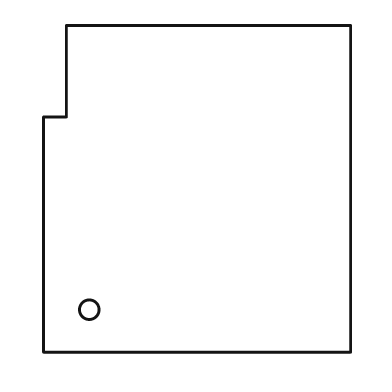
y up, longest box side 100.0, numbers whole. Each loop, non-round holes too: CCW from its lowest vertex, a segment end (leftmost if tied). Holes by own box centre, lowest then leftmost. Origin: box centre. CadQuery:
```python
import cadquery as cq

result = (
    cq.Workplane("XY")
    .moveTo(-47.0, -50.0)
    .lineTo(47.0, -50.0)
    .lineTo(47.0, 50.0)
    .lineTo(-40.0, 50.0)
    .lineTo(-40.0, 22.0)
    .lineTo(-47.0, 22.0)
    .close()
    .moveTo(-33.0, -37.0)
    .circle(3.0)
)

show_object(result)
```